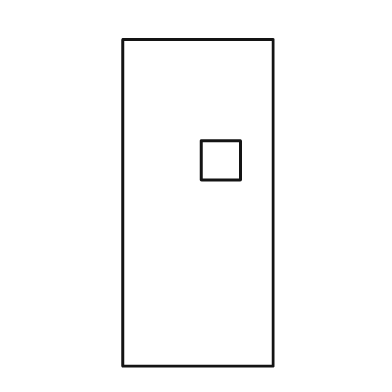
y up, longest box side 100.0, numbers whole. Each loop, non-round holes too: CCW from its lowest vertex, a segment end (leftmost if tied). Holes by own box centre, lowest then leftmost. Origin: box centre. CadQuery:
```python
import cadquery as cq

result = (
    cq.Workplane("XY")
    .moveTo(-23.0, -50.0)
    .lineTo(23.0, -50.0)
    .lineTo(23.0, 50.0)
    .lineTo(-23.0, 50.0)
    .close()
    .moveTo(1.0, 7.0)
    .lineTo(13.0, 7.0)
    .lineTo(13.0, 19.0)
    .lineTo(1.0, 19.0)
    .close()
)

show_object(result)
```